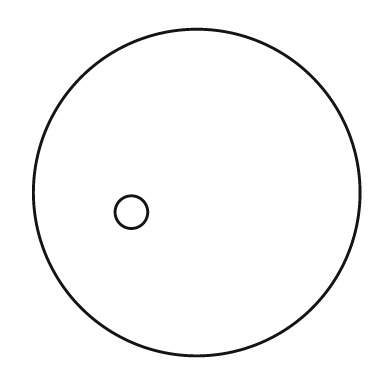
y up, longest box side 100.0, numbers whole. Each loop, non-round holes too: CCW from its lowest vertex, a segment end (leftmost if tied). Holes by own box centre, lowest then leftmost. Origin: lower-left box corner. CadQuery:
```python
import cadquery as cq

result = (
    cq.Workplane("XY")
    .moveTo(50.0, 50.0)
    .circle(50.0)
    .moveTo(30.0, 44.0)
    .circle(5.0)
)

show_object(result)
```